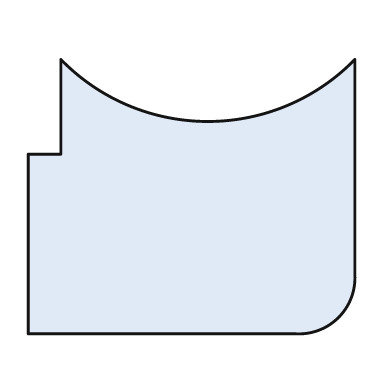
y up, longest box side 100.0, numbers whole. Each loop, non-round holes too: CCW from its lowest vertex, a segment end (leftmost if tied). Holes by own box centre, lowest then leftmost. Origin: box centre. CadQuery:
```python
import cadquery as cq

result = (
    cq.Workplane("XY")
    .moveTo(-50.0, -42.0)
    .lineTo(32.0, -42.0)
    .threePointArc((45.0, -37.0), (50.0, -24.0))
    .lineTo(50.0, 42.0)
    .threePointArc((5.0, 23.0), (-40.0, 42.0))
    .lineTo(-40.0, 13.0)
    .lineTo(-50.0, 13.0)
    .close()
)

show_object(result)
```